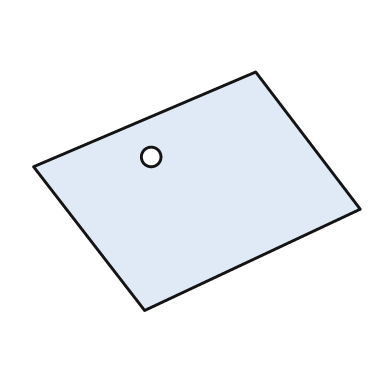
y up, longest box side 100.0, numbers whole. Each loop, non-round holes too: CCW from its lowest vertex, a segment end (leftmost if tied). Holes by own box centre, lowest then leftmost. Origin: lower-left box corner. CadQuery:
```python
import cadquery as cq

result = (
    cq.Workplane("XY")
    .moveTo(34.0, 0.0)
    .lineTo(100.0, 31.0)
    .lineTo(68.0, 73.0)
    .lineTo(0.0, 44.0)
    .close()
    .moveTo(36.0, 47.0)
    .circle(3.0)
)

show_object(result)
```